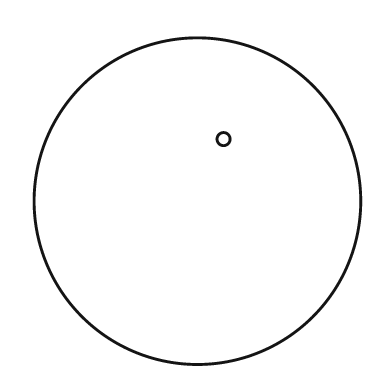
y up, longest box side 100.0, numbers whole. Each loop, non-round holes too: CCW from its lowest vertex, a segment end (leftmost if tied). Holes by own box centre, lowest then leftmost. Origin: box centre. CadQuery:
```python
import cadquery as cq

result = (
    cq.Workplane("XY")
    .moveTo(0.0, 0.0)
    .circle(50.0)
    .moveTo(8.0, 19.0)
    .circle(2.0)
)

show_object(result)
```